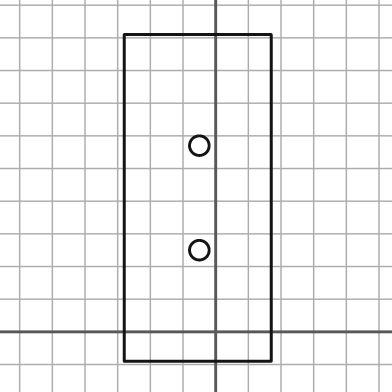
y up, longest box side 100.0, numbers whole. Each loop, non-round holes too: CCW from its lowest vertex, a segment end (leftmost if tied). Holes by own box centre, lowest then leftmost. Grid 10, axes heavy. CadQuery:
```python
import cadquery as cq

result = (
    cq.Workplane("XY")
    .moveTo(-28.0, -9.0)
    .lineTo(17.0, -9.0)
    .lineTo(17.0, 91.0)
    .lineTo(-28.0, 91.0)
    .close()
    .moveTo(-5.0, 25.0)
    .circle(3.0)
    .moveTo(-5.0, 57.0)
    .circle(3.0)
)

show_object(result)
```